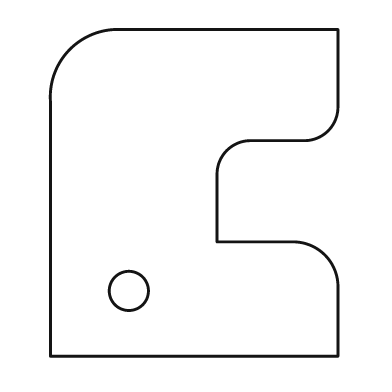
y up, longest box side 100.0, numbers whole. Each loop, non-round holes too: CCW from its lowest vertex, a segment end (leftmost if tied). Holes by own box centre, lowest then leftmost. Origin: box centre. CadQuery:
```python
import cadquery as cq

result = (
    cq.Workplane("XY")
    .moveTo(-44.0, -50.0)
    .lineTo(44.0, -50.0)
    .lineTo(44.0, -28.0)
    .threePointArc((40.0, -19.0), (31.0, -15.0))
    .lineTo(7.0, -15.0)
    .lineTo(7.0, 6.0)
    .threePointArc((10.0, 13.0), (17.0, 16.0))
    .lineTo(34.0, 16.0)
    .threePointArc((41.0, 19.0), (44.0, 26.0))
    .lineTo(44.0, 50.0)
    .lineTo(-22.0, 50.0)
    .threePointArc((-38.0, 44.0), (-44.0, 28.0))
    .close()
    .moveTo(-20.0, -30.0)
    .circle(6.0)
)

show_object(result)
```